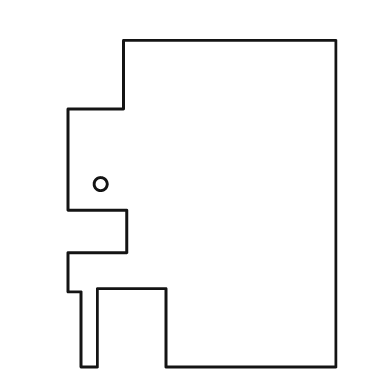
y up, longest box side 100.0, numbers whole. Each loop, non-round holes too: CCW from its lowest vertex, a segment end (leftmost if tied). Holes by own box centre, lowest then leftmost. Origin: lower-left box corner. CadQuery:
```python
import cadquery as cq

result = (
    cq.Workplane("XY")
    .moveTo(4.0, 0.0)
    .lineTo(9.0, 0.0)
    .lineTo(9.0, 24.0)
    .lineTo(30.0, 24.0)
    .lineTo(30.0, 0.0)
    .lineTo(82.0, 0.0)
    .lineTo(82.0, 100.0)
    .lineTo(17.0, 100.0)
    .lineTo(17.0, 79.0)
    .lineTo(0.0, 79.0)
    .lineTo(0.0, 48.0)
    .lineTo(18.0, 48.0)
    .lineTo(18.0, 35.0)
    .lineTo(0.0, 35.0)
    .lineTo(0.0, 23.0)
    .lineTo(4.0, 23.0)
    .close()
    .moveTo(10.0, 56.0)
    .circle(2.0)
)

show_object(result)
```